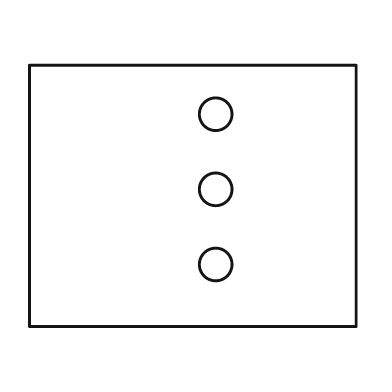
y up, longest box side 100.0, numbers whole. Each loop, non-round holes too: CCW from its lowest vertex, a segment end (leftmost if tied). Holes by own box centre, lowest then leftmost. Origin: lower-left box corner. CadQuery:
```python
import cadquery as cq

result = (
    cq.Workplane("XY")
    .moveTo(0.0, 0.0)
    .lineTo(100.0, 0.0)
    .lineTo(100.0, 80.0)
    .lineTo(0.0, 80.0)
    .close()
    .moveTo(57.0, 19.0)
    .circle(5.0)
    .moveTo(57.0, 42.0)
    .circle(5.0)
    .moveTo(57.0, 65.0)
    .circle(5.0)
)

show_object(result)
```